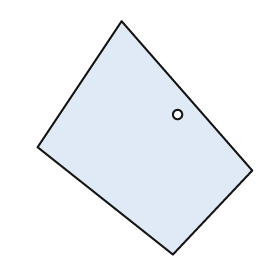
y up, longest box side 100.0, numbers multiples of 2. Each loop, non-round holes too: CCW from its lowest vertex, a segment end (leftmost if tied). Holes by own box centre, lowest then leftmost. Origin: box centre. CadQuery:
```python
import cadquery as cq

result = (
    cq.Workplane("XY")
    .moveTo(12.0, -50.0)
    .lineTo(46.0, -14.0)
    .lineTo(-10.0, 50.0)
    .lineTo(-46.0, -4.0)
    .close()
    .moveTo(14.0, 10.0)
    .circle(2.0)
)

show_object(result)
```